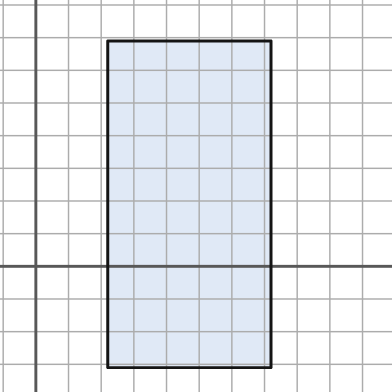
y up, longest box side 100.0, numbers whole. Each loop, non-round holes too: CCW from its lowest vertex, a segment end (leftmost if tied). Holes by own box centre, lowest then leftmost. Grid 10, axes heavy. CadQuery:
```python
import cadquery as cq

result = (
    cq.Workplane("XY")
    .moveTo(22.0, -31.0)
    .lineTo(72.0, -31.0)
    .lineTo(72.0, 69.0)
    .lineTo(22.0, 69.0)
    .close()
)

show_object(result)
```